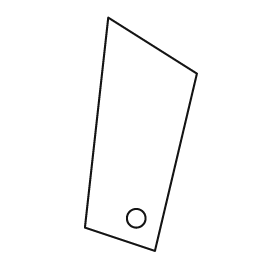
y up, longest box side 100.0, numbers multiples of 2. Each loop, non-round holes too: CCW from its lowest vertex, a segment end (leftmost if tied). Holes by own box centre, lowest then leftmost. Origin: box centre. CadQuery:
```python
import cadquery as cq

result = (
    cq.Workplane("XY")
    .moveTo(6.0, -50.0)
    .lineTo(24.0, 26.0)
    .lineTo(-14.0, 50.0)
    .lineTo(-24.0, -40.0)
    .close()
    .moveTo(-2.0, -36.0)
    .circle(4.0)
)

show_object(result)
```